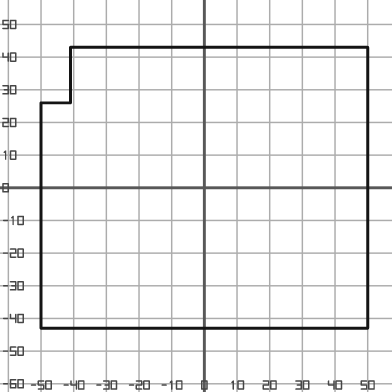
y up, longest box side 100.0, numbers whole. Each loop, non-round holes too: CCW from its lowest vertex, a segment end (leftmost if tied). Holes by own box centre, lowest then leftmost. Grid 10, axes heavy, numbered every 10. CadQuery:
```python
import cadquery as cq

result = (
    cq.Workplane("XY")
    .moveTo(-50.0, -43.0)
    .lineTo(50.0, -43.0)
    .lineTo(50.0, 43.0)
    .lineTo(-41.0, 43.0)
    .lineTo(-41.0, 26.0)
    .lineTo(-50.0, 26.0)
    .close()
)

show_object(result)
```